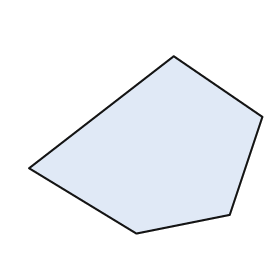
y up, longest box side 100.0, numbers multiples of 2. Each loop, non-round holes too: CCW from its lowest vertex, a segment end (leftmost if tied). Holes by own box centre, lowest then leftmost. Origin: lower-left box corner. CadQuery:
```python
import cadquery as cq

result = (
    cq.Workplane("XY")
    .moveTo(46.0, 0.0)
    .lineTo(86.0, 8.0)
    .lineTo(100.0, 50.0)
    .lineTo(62.0, 76.0)
    .lineTo(0.0, 28.0)
    .close()
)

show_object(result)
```